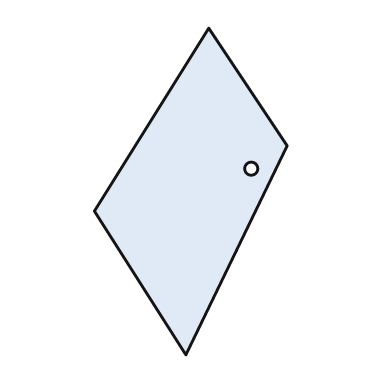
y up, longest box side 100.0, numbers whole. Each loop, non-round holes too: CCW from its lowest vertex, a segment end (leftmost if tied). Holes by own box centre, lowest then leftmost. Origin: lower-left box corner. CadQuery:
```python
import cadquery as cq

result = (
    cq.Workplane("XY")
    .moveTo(28.0, 0.0)
    .lineTo(59.0, 64.0)
    .lineTo(35.0, 100.0)
    .lineTo(0.0, 44.0)
    .close()
    .moveTo(48.0, 57.0)
    .circle(2.0)
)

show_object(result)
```